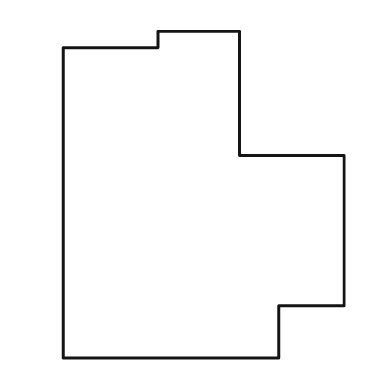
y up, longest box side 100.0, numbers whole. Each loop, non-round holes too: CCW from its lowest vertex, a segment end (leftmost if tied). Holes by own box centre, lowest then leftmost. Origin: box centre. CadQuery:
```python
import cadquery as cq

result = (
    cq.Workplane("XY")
    .moveTo(-43.0, -50.0)
    .lineTo(23.0, -50.0)
    .lineTo(23.0, -34.0)
    .lineTo(43.0, -34.0)
    .lineTo(43.0, 12.0)
    .lineTo(11.0, 12.0)
    .lineTo(11.0, 50.0)
    .lineTo(-14.0, 50.0)
    .lineTo(-14.0, 45.0)
    .lineTo(-43.0, 45.0)
    .close()
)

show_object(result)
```